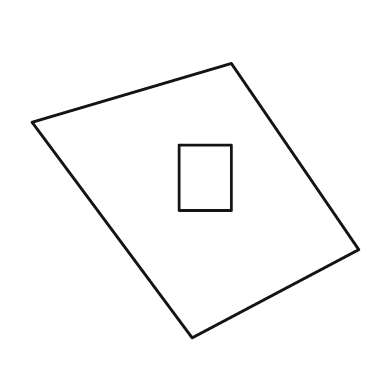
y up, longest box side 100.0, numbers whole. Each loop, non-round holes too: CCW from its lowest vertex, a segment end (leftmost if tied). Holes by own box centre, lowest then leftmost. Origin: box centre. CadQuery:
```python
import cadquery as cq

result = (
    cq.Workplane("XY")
    .moveTo(-1.0, -42.0)
    .lineTo(50.0, -15.0)
    .lineTo(11.0, 42.0)
    .lineTo(-50.0, 24.0)
    .close()
    .moveTo(-5.0, -3.0)
    .lineTo(11.0, -3.0)
    .lineTo(11.0, 17.0)
    .lineTo(-5.0, 17.0)
    .close()
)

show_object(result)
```